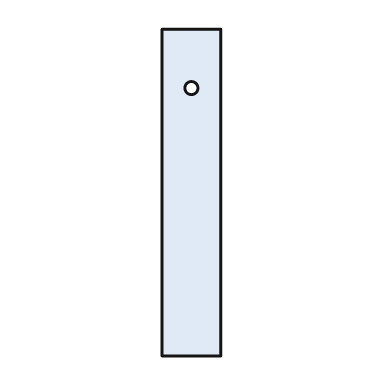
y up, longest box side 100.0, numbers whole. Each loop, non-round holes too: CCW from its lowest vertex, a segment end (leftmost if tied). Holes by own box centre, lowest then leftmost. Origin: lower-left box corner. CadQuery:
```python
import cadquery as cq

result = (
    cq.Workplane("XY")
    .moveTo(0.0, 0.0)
    .lineTo(18.0, 0.0)
    .lineTo(18.0, 100.0)
    .lineTo(0.0, 100.0)
    .close()
    .moveTo(9.0, 82.0)
    .circle(2.0)
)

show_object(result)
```